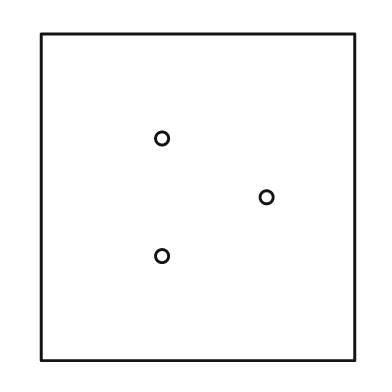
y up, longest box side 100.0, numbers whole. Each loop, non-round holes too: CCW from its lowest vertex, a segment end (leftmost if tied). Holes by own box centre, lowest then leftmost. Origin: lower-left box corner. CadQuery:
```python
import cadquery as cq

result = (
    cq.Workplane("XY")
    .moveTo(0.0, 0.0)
    .lineTo(96.0, 0.0)
    .lineTo(96.0, 100.0)
    .lineTo(0.0, 100.0)
    .close()
    .moveTo(37.0, 32.0)
    .circle(2.0)
    .moveTo(69.0, 50.0)
    .circle(2.0)
    .moveTo(37.0, 68.0)
    .circle(2.0)
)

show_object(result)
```